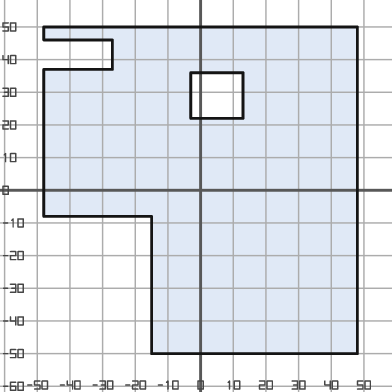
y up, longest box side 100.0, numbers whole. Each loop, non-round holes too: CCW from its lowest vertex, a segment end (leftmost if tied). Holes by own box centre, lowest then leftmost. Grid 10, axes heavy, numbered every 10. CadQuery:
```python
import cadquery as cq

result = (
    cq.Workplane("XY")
    .moveTo(-15.0, -50.0)
    .lineTo(48.0, -50.0)
    .lineTo(48.0, 50.0)
    .lineTo(-48.0, 50.0)
    .lineTo(-48.0, 46.0)
    .lineTo(-27.0, 46.0)
    .lineTo(-27.0, 37.0)
    .lineTo(-48.0, 37.0)
    .lineTo(-48.0, -8.0)
    .lineTo(-15.0, -8.0)
    .close()
    .moveTo(-3.0, 22.0)
    .lineTo(13.0, 22.0)
    .lineTo(13.0, 36.0)
    .lineTo(-3.0, 36.0)
    .close()
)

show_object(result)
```